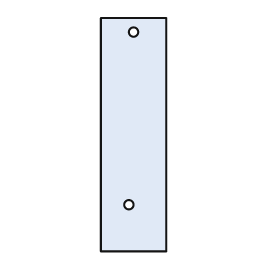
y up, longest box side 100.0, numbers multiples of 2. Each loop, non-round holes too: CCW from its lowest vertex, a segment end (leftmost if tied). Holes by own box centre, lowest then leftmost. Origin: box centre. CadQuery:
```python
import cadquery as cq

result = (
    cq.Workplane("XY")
    .moveTo(-14.0, -50.0)
    .lineTo(14.0, -50.0)
    .lineTo(14.0, 50.0)
    .lineTo(-14.0, 50.0)
    .close()
    .moveTo(-2.0, -30.0)
    .circle(2.0)
    .moveTo(0.0, 44.0)
    .circle(2.0)
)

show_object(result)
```